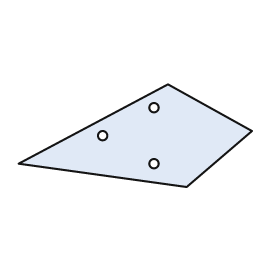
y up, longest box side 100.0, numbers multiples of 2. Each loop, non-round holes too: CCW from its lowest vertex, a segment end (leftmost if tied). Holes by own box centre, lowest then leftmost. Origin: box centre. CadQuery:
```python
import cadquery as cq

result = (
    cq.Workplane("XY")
    .moveTo(22.0, -22.0)
    .lineTo(50.0, 2.0)
    .lineTo(14.0, 22.0)
    .lineTo(-50.0, -12.0)
    .close()
    .moveTo(8.0, -12.0)
    .circle(2.0)
    .moveTo(-14.0, 0.0)
    .circle(2.0)
    .moveTo(8.0, 12.0)
    .circle(2.0)
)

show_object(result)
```